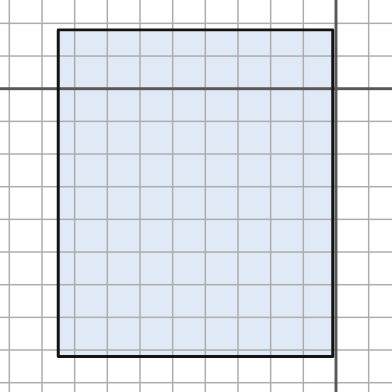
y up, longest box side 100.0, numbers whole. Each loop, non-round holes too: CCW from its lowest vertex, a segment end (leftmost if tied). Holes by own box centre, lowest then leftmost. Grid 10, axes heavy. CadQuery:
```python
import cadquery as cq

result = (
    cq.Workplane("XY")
    .moveTo(-85.0, -82.0)
    .lineTo(-1.0, -82.0)
    .lineTo(-1.0, 18.0)
    .lineTo(-85.0, 18.0)
    .close()
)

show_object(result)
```